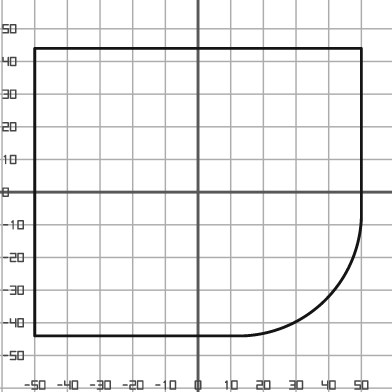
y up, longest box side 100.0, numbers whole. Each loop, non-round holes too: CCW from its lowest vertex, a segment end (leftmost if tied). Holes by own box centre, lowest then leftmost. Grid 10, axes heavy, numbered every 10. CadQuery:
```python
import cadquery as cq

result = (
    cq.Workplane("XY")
    .moveTo(-50.0, -44.0)
    .lineTo(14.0, -44.0)
    .threePointArc((39.0, -33.0), (50.0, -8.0))
    .lineTo(50.0, 44.0)
    .lineTo(-50.0, 44.0)
    .close()
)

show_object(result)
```